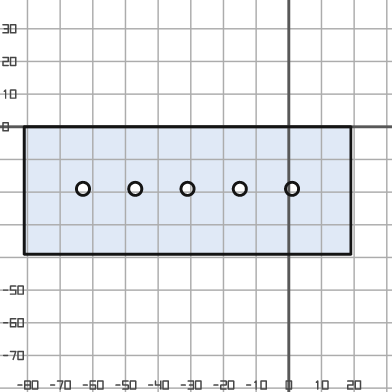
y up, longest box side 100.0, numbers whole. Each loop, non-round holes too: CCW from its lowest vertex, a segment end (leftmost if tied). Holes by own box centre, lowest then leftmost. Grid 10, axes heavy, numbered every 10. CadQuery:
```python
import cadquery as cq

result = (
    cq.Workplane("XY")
    .moveTo(-81.0, -39.0)
    .lineTo(19.0, -39.0)
    .lineTo(19.0, 0.0)
    .lineTo(-81.0, 0.0)
    .close()
    .moveTo(-63.0, -19.0)
    .circle(2.0)
    .moveTo(-47.0, -19.0)
    .circle(2.0)
    .moveTo(-31.0, -19.0)
    .circle(2.0)
    .moveTo(-15.0, -19.0)
    .circle(2.0)
    .moveTo(1.0, -19.0)
    .circle(2.0)
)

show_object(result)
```